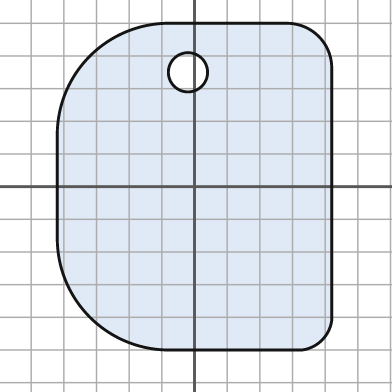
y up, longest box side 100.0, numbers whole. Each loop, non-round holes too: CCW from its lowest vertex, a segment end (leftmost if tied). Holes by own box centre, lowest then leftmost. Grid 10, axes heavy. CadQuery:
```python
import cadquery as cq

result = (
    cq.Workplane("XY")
    .moveTo(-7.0, -50.0)
    .lineTo(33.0, -50.0)
    .threePointArc((39.0, -47.0), (42.0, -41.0))
    .lineTo(42.0, 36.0)
    .threePointArc((38.0, 46.0), (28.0, 50.0))
    .lineTo(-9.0, 50.0)
    .threePointArc((-32.0, 40.0), (-42.0, 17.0))
    .lineTo(-42.0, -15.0)
    .threePointArc((-32.0, -40.0), (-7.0, -50.0))
    .close()
    .moveTo(-2.0, 35.0)
    .circle(6.0)
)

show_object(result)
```